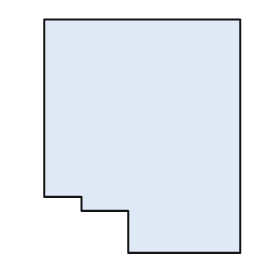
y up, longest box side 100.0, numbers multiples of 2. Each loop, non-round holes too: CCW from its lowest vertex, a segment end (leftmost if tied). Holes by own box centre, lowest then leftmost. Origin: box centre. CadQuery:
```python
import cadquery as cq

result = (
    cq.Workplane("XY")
    .moveTo(-6.0, -50.0)
    .lineTo(42.0, -50.0)
    .lineTo(42.0, 50.0)
    .lineTo(-42.0, 50.0)
    .lineTo(-42.0, -26.0)
    .lineTo(-26.0, -26.0)
    .lineTo(-26.0, -32.0)
    .lineTo(-6.0, -32.0)
    .close()
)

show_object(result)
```